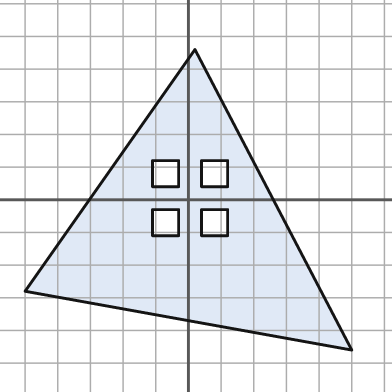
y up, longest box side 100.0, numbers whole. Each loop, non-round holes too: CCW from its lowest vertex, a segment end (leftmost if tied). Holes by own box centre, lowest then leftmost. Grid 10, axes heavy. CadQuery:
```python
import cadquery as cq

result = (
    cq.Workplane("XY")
    .moveTo(50.0, -46.0)
    .lineTo(2.0, 46.0)
    .lineTo(-50.0, -28.0)
    .close()
    .moveTo(-11.0, -11.0)
    .lineTo(-3.0, -11.0)
    .lineTo(-3.0, -3.0)
    .lineTo(-11.0, -3.0)
    .close()
    .moveTo(4.0, -11.0)
    .lineTo(12.0, -11.0)
    .lineTo(12.0, -3.0)
    .lineTo(4.0, -3.0)
    .close()
    .moveTo(-11.0, 4.0)
    .lineTo(-3.0, 4.0)
    .lineTo(-3.0, 12.0)
    .lineTo(-11.0, 12.0)
    .close()
    .moveTo(4.0, 4.0)
    .lineTo(12.0, 4.0)
    .lineTo(12.0, 12.0)
    .lineTo(4.0, 12.0)
    .close()
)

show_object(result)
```